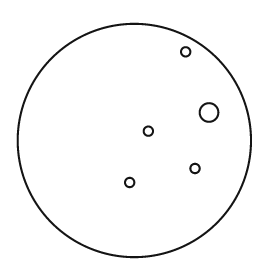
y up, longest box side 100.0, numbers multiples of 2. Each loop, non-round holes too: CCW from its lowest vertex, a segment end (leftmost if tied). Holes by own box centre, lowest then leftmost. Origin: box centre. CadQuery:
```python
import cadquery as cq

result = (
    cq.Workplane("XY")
    .moveTo(0.0, 0.0)
    .circle(50.0)
    .moveTo(-2.0, -18.0)
    .circle(2.0)
    .moveTo(26.0, -12.0)
    .circle(2.0)
    .moveTo(6.0, 4.0)
    .circle(2.0)
    .moveTo(32.0, 12.0)
    .circle(4.0)
    .moveTo(22.0, 38.0)
    .circle(2.0)
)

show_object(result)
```